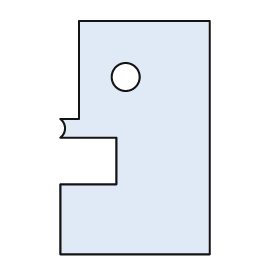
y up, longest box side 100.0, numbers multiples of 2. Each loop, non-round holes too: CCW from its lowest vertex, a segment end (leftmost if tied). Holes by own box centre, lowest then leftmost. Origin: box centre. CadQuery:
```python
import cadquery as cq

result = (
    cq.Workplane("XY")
    .moveTo(-32.0, -50.0)
    .lineTo(32.0, -50.0)
    .lineTo(32.0, 50.0)
    .lineTo(-24.0, 50.0)
    .lineTo(-24.0, 8.0)
    .lineTo(-32.0, 8.0)
    .threePointArc((-30.0, 4.0), (-32.0, 0.0))
    .lineTo(-8.0, 0.0)
    .lineTo(-8.0, -20.0)
    .lineTo(-32.0, -20.0)
    .close()
    .moveTo(-4.0, 26.0)
    .circle(6.0)
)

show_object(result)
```